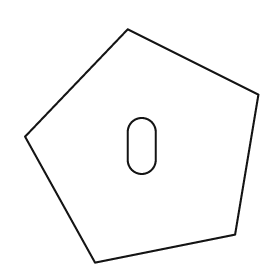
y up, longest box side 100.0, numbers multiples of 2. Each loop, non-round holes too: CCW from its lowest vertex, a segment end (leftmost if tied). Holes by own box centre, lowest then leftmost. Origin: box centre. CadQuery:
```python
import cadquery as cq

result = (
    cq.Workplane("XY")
    .moveTo(-20.0, -50.0)
    .lineTo(40.0, -38.0)
    .lineTo(50.0, 22.0)
    .lineTo(-6.0, 50.0)
    .lineTo(-50.0, 4.0)
    .close()
    .moveTo(-6.0, -6.0)
    .threePointArc((0.0, -12.0), (6.0, -6.0))
    .lineTo(6.0, 6.0)
    .threePointArc((0.0, 12.0), (-6.0, 6.0))
    .close()
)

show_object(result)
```